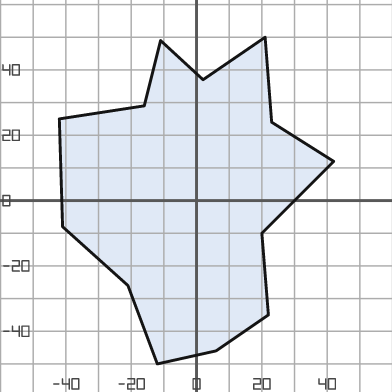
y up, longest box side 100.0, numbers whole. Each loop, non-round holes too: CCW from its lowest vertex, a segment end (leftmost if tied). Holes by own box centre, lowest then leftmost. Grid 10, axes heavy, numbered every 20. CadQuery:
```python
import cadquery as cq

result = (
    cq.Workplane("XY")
    .moveTo(-12.0, -50.0)
    .lineTo(6.0, -46.0)
    .lineTo(22.0, -35.0)
    .lineTo(20.0, -10.0)
    .lineTo(42.0, 12.0)
    .lineTo(23.0, 24.0)
    .lineTo(21.0, 50.0)
    .lineTo(2.0, 37.0)
    .lineTo(-11.0, 49.0)
    .lineTo(-16.0, 29.0)
    .lineTo(-42.0, 25.0)
    .lineTo(-41.0, -8.0)
    .lineTo(-21.0, -26.0)
    .close()
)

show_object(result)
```